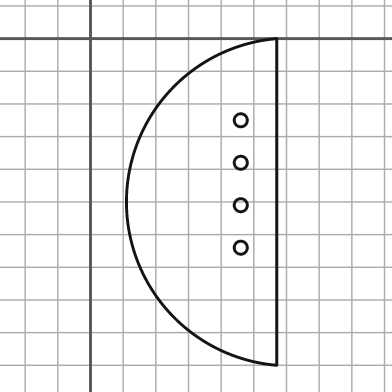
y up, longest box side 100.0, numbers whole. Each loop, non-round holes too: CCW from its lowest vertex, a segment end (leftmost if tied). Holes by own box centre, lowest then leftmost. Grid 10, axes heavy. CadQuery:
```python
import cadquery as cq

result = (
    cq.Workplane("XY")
    .moveTo(57.0, -100.0)
    .lineTo(57.0, 0.0)
    .threePointArc((11.0, -50.0), (57.0, -100.0))
    .close()
    .moveTo(46.0, -64.0)
    .circle(2.0)
    .moveTo(46.0, -51.0)
    .circle(2.0)
    .moveTo(46.0, -38.0)
    .circle(2.0)
    .moveTo(46.0, -25.0)
    .circle(2.0)
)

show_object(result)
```